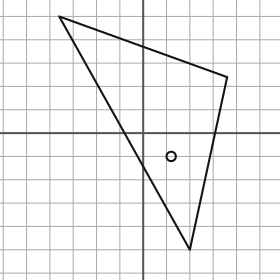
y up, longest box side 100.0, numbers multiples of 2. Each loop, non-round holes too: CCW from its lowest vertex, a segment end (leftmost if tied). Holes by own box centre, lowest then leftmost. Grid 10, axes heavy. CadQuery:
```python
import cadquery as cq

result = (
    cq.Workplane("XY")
    .moveTo(20.0, -50.0)
    .lineTo(36.0, 24.0)
    .lineTo(-36.0, 50.0)
    .close()
    .moveTo(12.0, -10.0)
    .circle(2.0)
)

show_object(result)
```